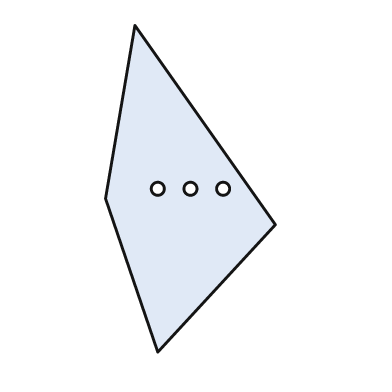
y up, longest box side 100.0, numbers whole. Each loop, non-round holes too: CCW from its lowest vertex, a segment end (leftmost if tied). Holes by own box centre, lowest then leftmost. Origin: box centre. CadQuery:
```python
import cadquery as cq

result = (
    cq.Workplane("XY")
    .moveTo(-10.0, -50.0)
    .lineTo(26.0, -11.0)
    .lineTo(-17.0, 50.0)
    .lineTo(-26.0, -3.0)
    .close()
    .moveTo(-10.0, 0.0)
    .circle(2.0)
    .moveTo(0.0, 0.0)
    .circle(2.0)
    .moveTo(10.0, 0.0)
    .circle(2.0)
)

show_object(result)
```